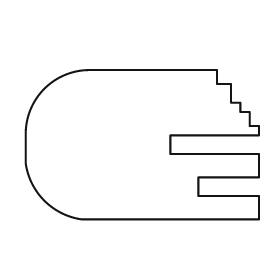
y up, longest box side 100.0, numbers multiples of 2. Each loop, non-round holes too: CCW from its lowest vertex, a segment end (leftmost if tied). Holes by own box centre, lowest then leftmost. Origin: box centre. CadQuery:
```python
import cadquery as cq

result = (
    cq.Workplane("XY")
    .moveTo(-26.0, -32.0)
    .lineTo(50.0, -32.0)
    .lineTo(50.0, -22.0)
    .lineTo(24.0, -22.0)
    .lineTo(24.0, -14.0)
    .lineTo(50.0, -14.0)
    .lineTo(50.0, -4.0)
    .lineTo(12.0, -4.0)
    .lineTo(12.0, 4.0)
    .lineTo(50.0, 4.0)
    .lineTo(50.0, 8.0)
    .lineTo(46.0, 8.0)
    .lineTo(46.0, 14.0)
    .lineTo(42.0, 14.0)
    .lineTo(42.0, 18.0)
    .lineTo(38.0, 18.0)
    .lineTo(38.0, 26.0)
    .lineTo(32.0, 26.0)
    .lineTo(32.0, 32.0)
    .lineTo(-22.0, 32.0)
    .threePointArc((-42.0, 24.0), (-50.0, 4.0))
    .lineTo(-50.0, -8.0)
    .threePointArc((-42.0, -24.0), (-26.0, -32.0))
    .close()
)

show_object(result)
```